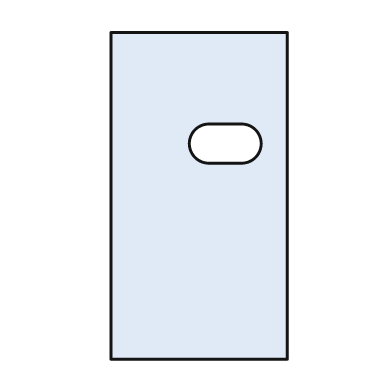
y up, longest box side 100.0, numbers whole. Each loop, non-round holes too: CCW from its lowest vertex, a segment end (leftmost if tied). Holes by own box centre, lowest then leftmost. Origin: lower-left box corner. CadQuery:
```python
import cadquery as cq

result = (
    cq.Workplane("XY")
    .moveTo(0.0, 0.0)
    .lineTo(54.0, 0.0)
    .lineTo(54.0, 100.0)
    .lineTo(0.0, 100.0)
    .close()
    .moveTo(30.0, 60.0)
    .lineTo(40.0, 60.0)
    .threePointArc((46.0, 66.0), (40.0, 72.0))
    .lineTo(30.0, 72.0)
    .threePointArc((24.0, 66.0), (30.0, 60.0))
    .close()
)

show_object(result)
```